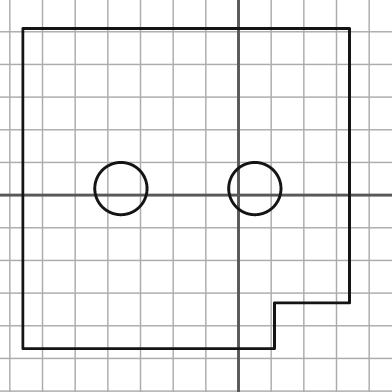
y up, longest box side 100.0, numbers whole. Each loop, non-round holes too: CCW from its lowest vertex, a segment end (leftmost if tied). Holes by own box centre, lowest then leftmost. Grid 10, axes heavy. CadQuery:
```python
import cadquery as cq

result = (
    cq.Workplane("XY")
    .moveTo(-66.0, -47.0)
    .lineTo(11.0, -47.0)
    .lineTo(11.0, -33.0)
    .lineTo(34.0, -33.0)
    .lineTo(34.0, 51.0)
    .lineTo(-66.0, 51.0)
    .close()
    .moveTo(-36.0, 2.0)
    .circle(8.0)
    .moveTo(5.0, 2.0)
    .circle(8.0)
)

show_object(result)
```